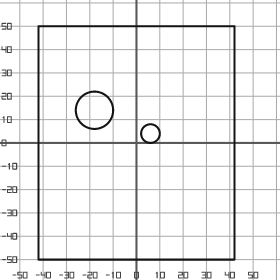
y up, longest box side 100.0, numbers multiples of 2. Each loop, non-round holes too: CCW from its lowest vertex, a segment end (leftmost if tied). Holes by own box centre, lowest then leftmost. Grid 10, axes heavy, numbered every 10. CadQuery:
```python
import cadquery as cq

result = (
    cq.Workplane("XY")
    .moveTo(-42.0, -50.0)
    .lineTo(42.0, -50.0)
    .lineTo(42.0, 50.0)
    .lineTo(-42.0, 50.0)
    .close()
    .moveTo(6.0, 4.0)
    .circle(4.0)
    .moveTo(-18.0, 14.0)
    .circle(8.0)
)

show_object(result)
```